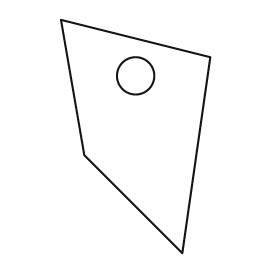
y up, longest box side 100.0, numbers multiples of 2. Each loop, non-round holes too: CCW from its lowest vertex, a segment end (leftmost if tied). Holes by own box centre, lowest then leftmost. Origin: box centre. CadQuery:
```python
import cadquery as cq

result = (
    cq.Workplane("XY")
    .moveTo(20.0, -50.0)
    .lineTo(32.0, 34.0)
    .lineTo(-32.0, 50.0)
    .lineTo(-22.0, -8.0)
    .close()
    .moveTo(0.0, 26.0)
    .circle(8.0)
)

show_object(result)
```